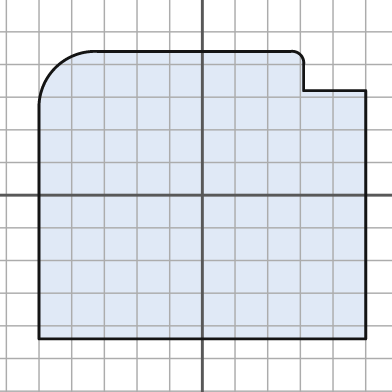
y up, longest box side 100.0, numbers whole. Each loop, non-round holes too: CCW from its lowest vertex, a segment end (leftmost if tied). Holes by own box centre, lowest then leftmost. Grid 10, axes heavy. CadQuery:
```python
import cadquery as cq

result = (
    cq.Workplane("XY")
    .moveTo(-50.0, -44.0)
    .lineTo(50.0, -44.0)
    .lineTo(50.0, 32.0)
    .lineTo(31.0, 32.0)
    .lineTo(31.0, 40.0)
    .threePointArc((30.0, 43.0), (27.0, 44.0))
    .lineTo(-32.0, 44.0)
    .threePointArc((-45.0, 39.0), (-50.0, 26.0))
    .close()
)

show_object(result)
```